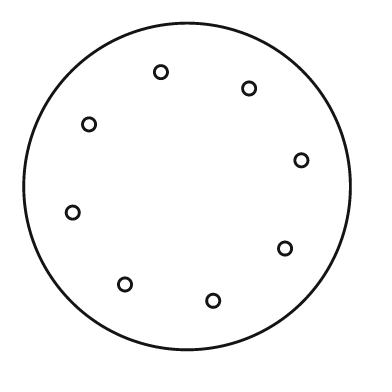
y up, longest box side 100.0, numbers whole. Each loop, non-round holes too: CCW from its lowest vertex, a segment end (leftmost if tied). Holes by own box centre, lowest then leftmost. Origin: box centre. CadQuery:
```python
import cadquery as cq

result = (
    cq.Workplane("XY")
    .moveTo(0.0, 0.0)
    .circle(50.0)
    .moveTo(8.0, -35.0)
    .circle(2.0)
    .moveTo(-19.0, -30.0)
    .circle(2.0)
    .moveTo(30.0, -19.0)
    .circle(2.0)
    .moveTo(-35.0, -8.0)
    .circle(2.0)
    .moveTo(35.0, 8.0)
    .circle(2.0)
    .moveTo(-30.0, 19.0)
    .circle(2.0)
    .moveTo(19.0, 30.0)
    .circle(2.0)
    .moveTo(-8.0, 35.0)
    .circle(2.0)
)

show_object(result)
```